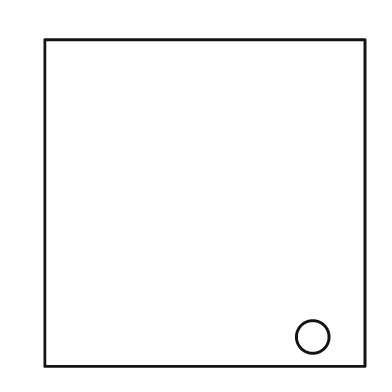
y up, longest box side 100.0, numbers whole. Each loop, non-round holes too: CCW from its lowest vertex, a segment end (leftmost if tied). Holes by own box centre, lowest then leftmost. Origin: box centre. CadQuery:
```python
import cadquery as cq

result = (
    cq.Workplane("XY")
    .moveTo(-49.0, -50.0)
    .lineTo(49.0, -50.0)
    .lineTo(49.0, 50.0)
    .lineTo(-49.0, 50.0)
    .close()
    .moveTo(33.0, -41.0)
    .circle(5.0)
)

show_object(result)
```